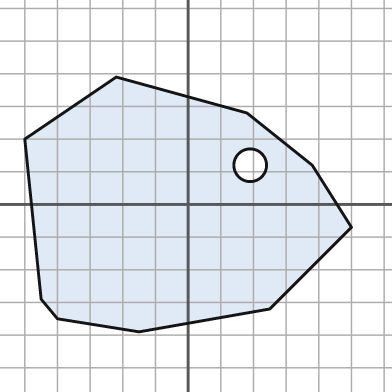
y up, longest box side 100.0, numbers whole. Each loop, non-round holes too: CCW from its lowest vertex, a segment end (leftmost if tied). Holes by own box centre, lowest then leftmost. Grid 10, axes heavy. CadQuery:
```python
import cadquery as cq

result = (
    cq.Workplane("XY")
    .moveTo(-15.0, -39.0)
    .lineTo(25.0, -32.0)
    .lineTo(50.0, -7.0)
    .lineTo(38.0, 12.0)
    .lineTo(18.0, 28.0)
    .lineTo(-22.0, 39.0)
    .lineTo(-50.0, 20.0)
    .lineTo(-45.0, -29.0)
    .lineTo(-40.0, -35.0)
    .close()
    .moveTo(19.0, 12.0)
    .circle(5.0)
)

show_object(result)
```